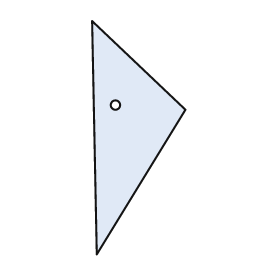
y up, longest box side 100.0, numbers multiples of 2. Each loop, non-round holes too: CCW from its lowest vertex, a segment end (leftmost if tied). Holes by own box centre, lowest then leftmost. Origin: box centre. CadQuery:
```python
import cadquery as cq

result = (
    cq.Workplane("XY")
    .moveTo(-18.0, -50.0)
    .lineTo(20.0, 12.0)
    .lineTo(-20.0, 50.0)
    .close()
    .moveTo(-10.0, 14.0)
    .circle(2.0)
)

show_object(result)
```